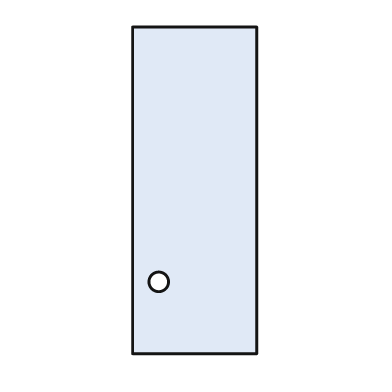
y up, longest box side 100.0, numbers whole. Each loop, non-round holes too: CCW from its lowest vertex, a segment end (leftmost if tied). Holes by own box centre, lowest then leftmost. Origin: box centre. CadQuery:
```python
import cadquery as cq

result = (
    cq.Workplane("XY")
    .moveTo(-19.0, -50.0)
    .lineTo(19.0, -50.0)
    .lineTo(19.0, 50.0)
    .lineTo(-19.0, 50.0)
    .close()
    .moveTo(-11.0, -28.0)
    .circle(3.0)
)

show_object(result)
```